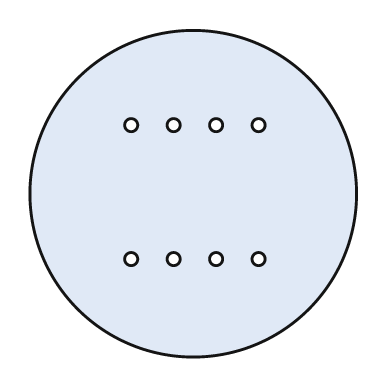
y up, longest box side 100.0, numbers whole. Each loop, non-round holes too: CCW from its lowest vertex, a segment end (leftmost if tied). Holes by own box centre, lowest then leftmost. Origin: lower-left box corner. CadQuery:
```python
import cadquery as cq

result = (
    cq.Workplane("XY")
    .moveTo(50.0, 50.0)
    .circle(50.0)
    .moveTo(31.0, 30.0)
    .circle(2.0)
    .moveTo(44.0, 30.0)
    .circle(2.0)
    .moveTo(57.0, 30.0)
    .circle(2.0)
    .moveTo(70.0, 30.0)
    .circle(2.0)
    .moveTo(31.0, 71.0)
    .circle(2.0)
    .moveTo(44.0, 71.0)
    .circle(2.0)
    .moveTo(57.0, 71.0)
    .circle(2.0)
    .moveTo(70.0, 71.0)
    .circle(2.0)
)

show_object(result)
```